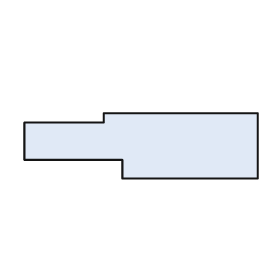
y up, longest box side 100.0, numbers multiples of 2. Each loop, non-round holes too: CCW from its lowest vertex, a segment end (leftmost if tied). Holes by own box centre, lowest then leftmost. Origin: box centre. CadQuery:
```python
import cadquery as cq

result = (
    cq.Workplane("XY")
    .moveTo(-8.0, -14.0)
    .lineTo(50.0, -14.0)
    .lineTo(50.0, 14.0)
    .lineTo(-16.0, 14.0)
    .lineTo(-16.0, 10.0)
    .lineTo(-50.0, 10.0)
    .lineTo(-50.0, -6.0)
    .lineTo(-8.0, -6.0)
    .close()
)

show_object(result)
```